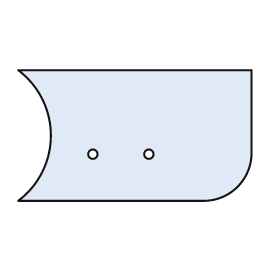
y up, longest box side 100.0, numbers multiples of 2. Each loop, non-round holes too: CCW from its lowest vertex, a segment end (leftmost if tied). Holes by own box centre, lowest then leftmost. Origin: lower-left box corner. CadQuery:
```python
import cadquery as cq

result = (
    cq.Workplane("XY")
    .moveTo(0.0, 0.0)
    .lineTo(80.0, 0.0)
    .threePointArc((94.0, 6.0), (100.0, 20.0))
    .lineTo(100.0, 56.0)
    .lineTo(0.0, 56.0)
    .threePointArc((14.0, 28.0), (0.0, 0.0))
    .close()
    .moveTo(32.0, 20.0)
    .circle(2.0)
    .moveTo(56.0, 20.0)
    .circle(2.0)
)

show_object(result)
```